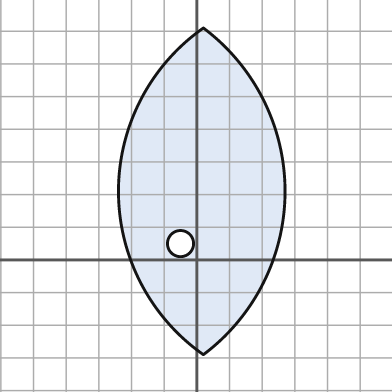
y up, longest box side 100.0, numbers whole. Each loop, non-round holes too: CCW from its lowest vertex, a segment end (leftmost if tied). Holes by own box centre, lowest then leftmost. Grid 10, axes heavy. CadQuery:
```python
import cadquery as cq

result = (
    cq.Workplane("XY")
    .moveTo(2.0, -29.0)
    .threePointArc((27.0, 21.0), (2.0, 71.0))
    .threePointArc((-24.0, 21.0), (2.0, -29.0))
    .close()
    .moveTo(-5.0, 5.0)
    .circle(4.0)
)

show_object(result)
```